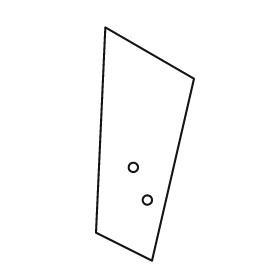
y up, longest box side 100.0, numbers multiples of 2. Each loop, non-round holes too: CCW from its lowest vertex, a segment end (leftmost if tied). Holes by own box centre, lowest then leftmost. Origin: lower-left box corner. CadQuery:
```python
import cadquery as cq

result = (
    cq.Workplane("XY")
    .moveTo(24.0, 0.0)
    .lineTo(42.0, 78.0)
    .lineTo(4.0, 100.0)
    .lineTo(0.0, 12.0)
    .close()
    .moveTo(22.0, 26.0)
    .circle(2.0)
    .moveTo(16.0, 40.0)
    .circle(2.0)
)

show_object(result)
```